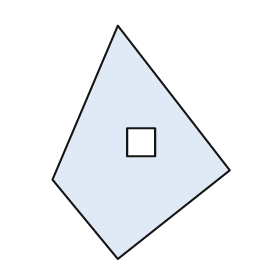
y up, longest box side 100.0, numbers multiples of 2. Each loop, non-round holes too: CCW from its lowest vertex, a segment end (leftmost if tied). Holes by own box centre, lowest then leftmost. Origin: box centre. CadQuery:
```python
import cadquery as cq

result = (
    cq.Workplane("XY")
    .moveTo(-10.0, -50.0)
    .lineTo(38.0, -12.0)
    .lineTo(-10.0, 50.0)
    .lineTo(-38.0, -16.0)
    .close()
    .moveTo(-6.0, -6.0)
    .lineTo(6.0, -6.0)
    .lineTo(6.0, 6.0)
    .lineTo(-6.0, 6.0)
    .close()
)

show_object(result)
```